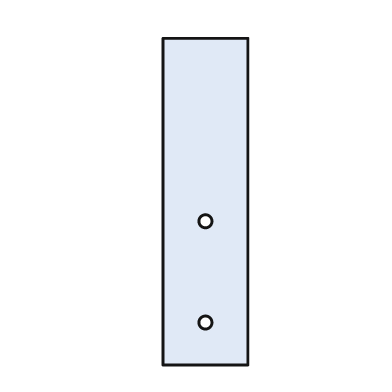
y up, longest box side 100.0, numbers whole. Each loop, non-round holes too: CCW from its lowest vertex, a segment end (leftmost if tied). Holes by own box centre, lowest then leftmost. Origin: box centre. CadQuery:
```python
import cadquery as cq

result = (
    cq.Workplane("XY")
    .moveTo(-13.0, -50.0)
    .lineTo(13.0, -50.0)
    .lineTo(13.0, 50.0)
    .lineTo(-13.0, 50.0)
    .close()
    .moveTo(0.0, -37.0)
    .circle(2.0)
    .moveTo(0.0, -6.0)
    .circle(2.0)
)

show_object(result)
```